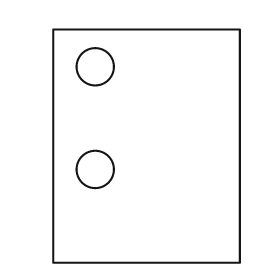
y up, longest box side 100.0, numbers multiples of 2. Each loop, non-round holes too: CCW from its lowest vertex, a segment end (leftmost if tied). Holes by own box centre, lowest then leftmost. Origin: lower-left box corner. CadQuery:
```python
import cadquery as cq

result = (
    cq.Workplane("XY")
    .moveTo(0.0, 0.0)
    .lineTo(80.0, 0.0)
    .lineTo(80.0, 100.0)
    .lineTo(0.0, 100.0)
    .close()
    .moveTo(18.0, 40.0)
    .circle(8.0)
    .moveTo(18.0, 84.0)
    .circle(8.0)
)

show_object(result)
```